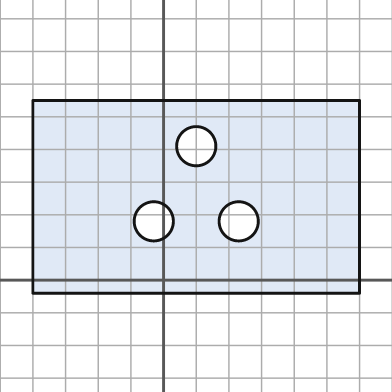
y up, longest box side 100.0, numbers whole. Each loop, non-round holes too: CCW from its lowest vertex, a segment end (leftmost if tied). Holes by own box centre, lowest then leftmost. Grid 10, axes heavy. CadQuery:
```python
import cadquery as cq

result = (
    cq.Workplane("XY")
    .moveTo(-40.0, -4.0)
    .lineTo(60.0, -4.0)
    .lineTo(60.0, 55.0)
    .lineTo(-40.0, 55.0)
    .close()
    .moveTo(-3.0, 18.0)
    .circle(6.0)
    .moveTo(23.0, 18.0)
    .circle(6.0)
    .moveTo(10.0, 41.0)
    .circle(6.0)
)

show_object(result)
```